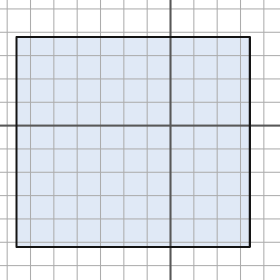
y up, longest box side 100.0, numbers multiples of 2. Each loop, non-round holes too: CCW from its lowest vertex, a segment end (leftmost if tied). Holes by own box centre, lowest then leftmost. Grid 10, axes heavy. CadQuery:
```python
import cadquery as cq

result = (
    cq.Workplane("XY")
    .moveTo(-66.0, -52.0)
    .lineTo(34.0, -52.0)
    .lineTo(34.0, 38.0)
    .lineTo(-66.0, 38.0)
    .close()
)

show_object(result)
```